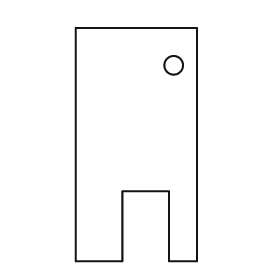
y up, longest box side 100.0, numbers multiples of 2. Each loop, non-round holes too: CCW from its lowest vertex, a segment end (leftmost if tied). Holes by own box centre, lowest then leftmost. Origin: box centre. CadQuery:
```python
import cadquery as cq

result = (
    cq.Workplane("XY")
    .moveTo(-26.0, -50.0)
    .lineTo(-6.0, -50.0)
    .lineTo(-6.0, -20.0)
    .lineTo(14.0, -20.0)
    .lineTo(14.0, -50.0)
    .lineTo(26.0, -50.0)
    .lineTo(26.0, 50.0)
    .lineTo(-26.0, 50.0)
    .close()
    .moveTo(16.0, 34.0)
    .circle(4.0)
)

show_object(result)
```